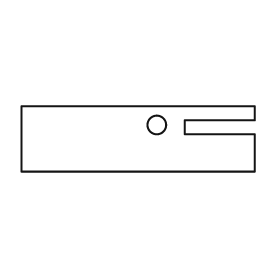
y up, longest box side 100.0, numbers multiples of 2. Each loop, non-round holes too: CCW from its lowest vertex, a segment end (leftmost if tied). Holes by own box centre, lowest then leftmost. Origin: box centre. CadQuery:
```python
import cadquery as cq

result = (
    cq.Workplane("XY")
    .moveTo(-50.0, -14.0)
    .lineTo(50.0, -14.0)
    .lineTo(50.0, 2.0)
    .lineTo(20.0, 2.0)
    .lineTo(20.0, 8.0)
    .lineTo(50.0, 8.0)
    .lineTo(50.0, 14.0)
    .lineTo(-50.0, 14.0)
    .close()
    .moveTo(8.0, 6.0)
    .circle(4.0)
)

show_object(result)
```